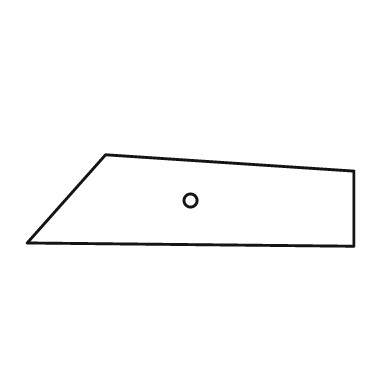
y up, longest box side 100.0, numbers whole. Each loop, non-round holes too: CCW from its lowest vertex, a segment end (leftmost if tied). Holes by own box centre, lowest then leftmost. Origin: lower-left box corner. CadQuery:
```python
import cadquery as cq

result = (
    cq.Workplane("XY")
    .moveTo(100.0, 0.0)
    .lineTo(100.0, 23.0)
    .lineTo(24.0, 28.0)
    .lineTo(0.0, 1.0)
    .close()
    .moveTo(50.0, 14.0)
    .circle(2.0)
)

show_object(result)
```